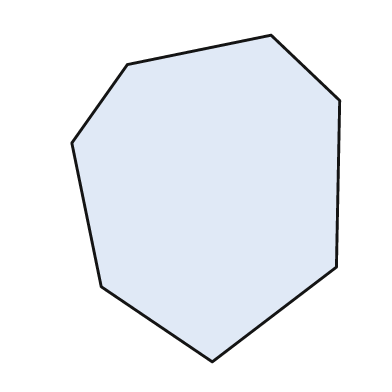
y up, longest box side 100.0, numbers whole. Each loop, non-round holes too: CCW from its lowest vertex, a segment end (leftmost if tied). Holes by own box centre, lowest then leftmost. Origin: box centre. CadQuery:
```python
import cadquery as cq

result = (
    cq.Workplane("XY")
    .moveTo(2.0, -50.0)
    .lineTo(40.0, -21.0)
    .lineTo(41.0, 30.0)
    .lineTo(20.0, 50.0)
    .lineTo(-24.0, 41.0)
    .lineTo(-41.0, 17.0)
    .lineTo(-32.0, -27.0)
    .close()
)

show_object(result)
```